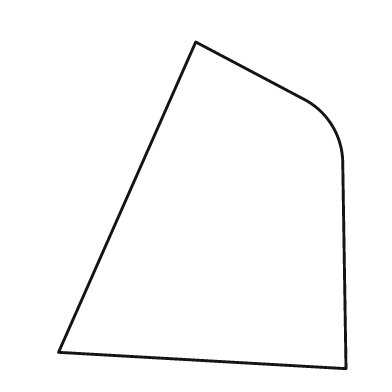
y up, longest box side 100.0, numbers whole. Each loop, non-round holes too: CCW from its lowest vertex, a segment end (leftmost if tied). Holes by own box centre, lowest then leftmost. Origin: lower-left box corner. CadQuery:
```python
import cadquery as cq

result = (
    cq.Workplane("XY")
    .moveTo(88.0, 0.0)
    .lineTo(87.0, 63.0)
    .threePointArc((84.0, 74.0), (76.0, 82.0))
    .lineTo(42.0, 100.0)
    .lineTo(0.0, 5.0)
    .close()
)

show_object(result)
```